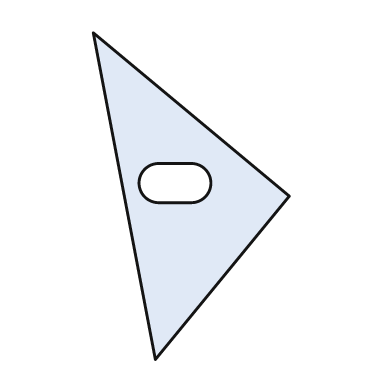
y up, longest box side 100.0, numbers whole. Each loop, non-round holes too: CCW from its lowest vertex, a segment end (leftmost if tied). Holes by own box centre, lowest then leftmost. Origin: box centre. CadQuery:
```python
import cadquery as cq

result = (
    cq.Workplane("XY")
    .moveTo(-11.0, -50.0)
    .lineTo(30.0, 0.0)
    .lineTo(-30.0, 50.0)
    .close()
    .moveTo(-10.0, -2.0)
    .lineTo(0.0, -2.0)
    .threePointArc((6.0, 4.0), (0.0, 10.0))
    .lineTo(-10.0, 10.0)
    .threePointArc((-16.0, 4.0), (-10.0, -2.0))
    .close()
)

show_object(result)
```